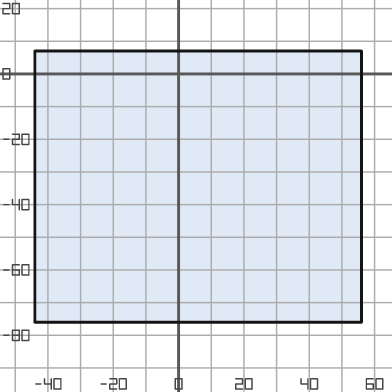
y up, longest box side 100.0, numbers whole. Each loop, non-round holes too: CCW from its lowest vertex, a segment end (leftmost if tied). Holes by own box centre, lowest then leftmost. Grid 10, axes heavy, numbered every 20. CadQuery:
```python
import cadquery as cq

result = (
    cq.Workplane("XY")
    .moveTo(-44.0, -76.0)
    .lineTo(56.0, -76.0)
    .lineTo(56.0, 7.0)
    .lineTo(-44.0, 7.0)
    .close()
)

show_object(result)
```